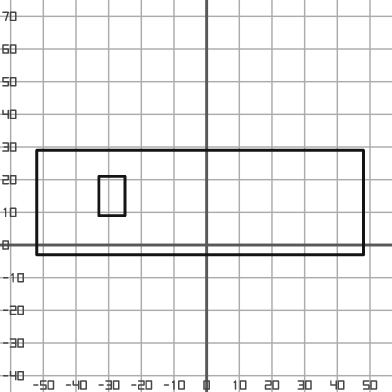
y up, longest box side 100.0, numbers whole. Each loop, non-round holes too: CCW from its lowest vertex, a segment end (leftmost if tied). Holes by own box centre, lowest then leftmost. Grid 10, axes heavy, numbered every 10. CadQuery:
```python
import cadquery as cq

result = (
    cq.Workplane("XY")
    .moveTo(-52.0, -3.0)
    .lineTo(48.0, -3.0)
    .lineTo(48.0, 29.0)
    .lineTo(-52.0, 29.0)
    .close()
    .moveTo(-33.0, 9.0)
    .lineTo(-25.0, 9.0)
    .lineTo(-25.0, 21.0)
    .lineTo(-33.0, 21.0)
    .close()
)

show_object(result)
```